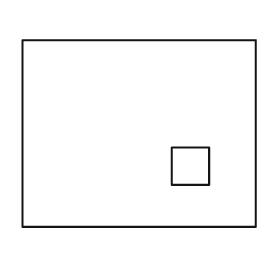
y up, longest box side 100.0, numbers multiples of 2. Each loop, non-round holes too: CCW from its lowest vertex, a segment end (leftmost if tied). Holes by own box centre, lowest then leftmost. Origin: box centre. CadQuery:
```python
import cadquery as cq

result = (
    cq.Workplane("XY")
    .moveTo(-50.0, -40.0)
    .lineTo(50.0, -40.0)
    .lineTo(50.0, 40.0)
    .lineTo(-50.0, 40.0)
    .close()
    .moveTo(14.0, -22.0)
    .lineTo(30.0, -22.0)
    .lineTo(30.0, -6.0)
    .lineTo(14.0, -6.0)
    .close()
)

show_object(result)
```